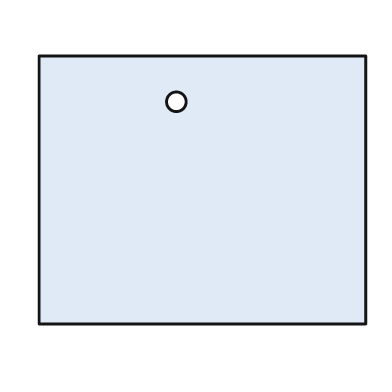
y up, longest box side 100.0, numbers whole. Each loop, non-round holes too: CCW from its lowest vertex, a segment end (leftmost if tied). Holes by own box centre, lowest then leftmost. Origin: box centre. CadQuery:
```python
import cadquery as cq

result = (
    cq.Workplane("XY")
    .moveTo(-50.0, -41.0)
    .lineTo(50.0, -41.0)
    .lineTo(50.0, 41.0)
    .lineTo(-50.0, 41.0)
    .close()
    .moveTo(-8.0, 27.0)
    .circle(3.0)
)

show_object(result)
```